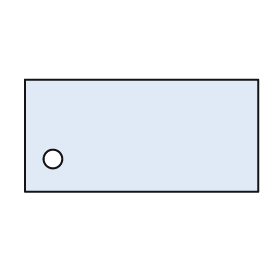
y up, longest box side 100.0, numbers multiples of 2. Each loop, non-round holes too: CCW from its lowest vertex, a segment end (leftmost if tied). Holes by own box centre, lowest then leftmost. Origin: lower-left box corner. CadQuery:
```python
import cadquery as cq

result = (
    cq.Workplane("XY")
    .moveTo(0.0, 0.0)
    .lineTo(100.0, 0.0)
    .lineTo(100.0, 48.0)
    .lineTo(0.0, 48.0)
    .close()
    .moveTo(12.0, 14.0)
    .circle(4.0)
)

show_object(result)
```